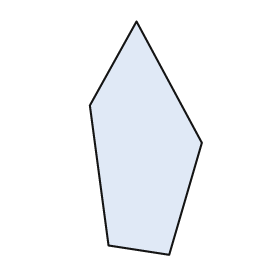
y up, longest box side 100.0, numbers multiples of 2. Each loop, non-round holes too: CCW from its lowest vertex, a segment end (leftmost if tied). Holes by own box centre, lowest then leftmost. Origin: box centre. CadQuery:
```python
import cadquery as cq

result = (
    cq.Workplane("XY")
    .moveTo(10.0, -50.0)
    .lineTo(24.0, -2.0)
    .lineTo(-4.0, 50.0)
    .lineTo(-24.0, 14.0)
    .lineTo(-16.0, -46.0)
    .close()
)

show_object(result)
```